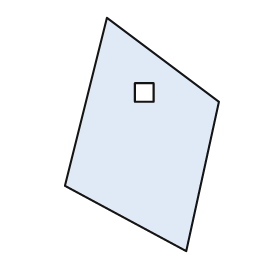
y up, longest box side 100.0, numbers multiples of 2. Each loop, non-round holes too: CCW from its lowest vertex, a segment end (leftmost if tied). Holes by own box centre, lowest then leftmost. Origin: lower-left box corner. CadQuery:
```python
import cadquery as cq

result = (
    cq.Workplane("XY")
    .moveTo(52.0, 0.0)
    .lineTo(66.0, 64.0)
    .lineTo(18.0, 100.0)
    .lineTo(0.0, 28.0)
    .close()
    .moveTo(30.0, 64.0)
    .lineTo(38.0, 64.0)
    .lineTo(38.0, 72.0)
    .lineTo(30.0, 72.0)
    .close()
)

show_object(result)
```